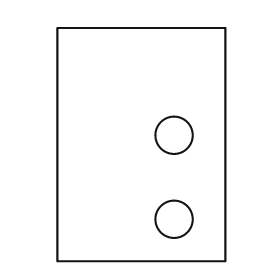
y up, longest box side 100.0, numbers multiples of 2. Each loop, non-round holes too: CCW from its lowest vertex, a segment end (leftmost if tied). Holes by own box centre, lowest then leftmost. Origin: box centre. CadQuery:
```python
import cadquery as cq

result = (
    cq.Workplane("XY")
    .moveTo(-36.0, -50.0)
    .lineTo(36.0, -50.0)
    .lineTo(36.0, 50.0)
    .lineTo(-36.0, 50.0)
    .close()
    .moveTo(14.0, -32.0)
    .circle(8.0)
    .moveTo(14.0, 4.0)
    .circle(8.0)
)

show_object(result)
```